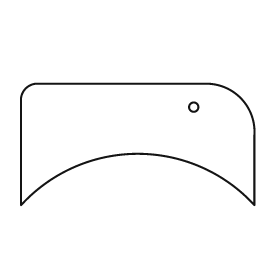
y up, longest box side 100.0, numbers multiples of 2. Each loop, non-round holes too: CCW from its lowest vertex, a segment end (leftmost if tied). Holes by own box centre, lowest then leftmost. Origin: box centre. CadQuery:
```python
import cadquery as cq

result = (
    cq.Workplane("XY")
    .moveTo(-50.0, -26.0)
    .threePointArc((0.0, -4.0), (50.0, -26.0))
    .lineTo(50.0, 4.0)
    .threePointArc((44.0, 20.0), (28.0, 26.0))
    .lineTo(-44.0, 26.0)
    .threePointArc((-48.0, 24.0), (-50.0, 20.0))
    .close()
    .moveTo(24.0, 16.0)
    .circle(2.0)
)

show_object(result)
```